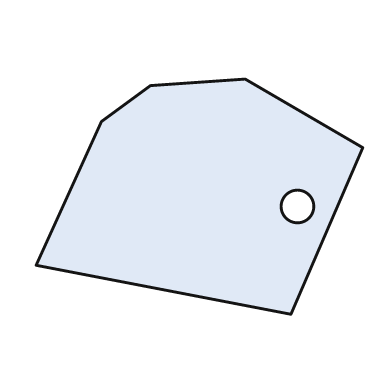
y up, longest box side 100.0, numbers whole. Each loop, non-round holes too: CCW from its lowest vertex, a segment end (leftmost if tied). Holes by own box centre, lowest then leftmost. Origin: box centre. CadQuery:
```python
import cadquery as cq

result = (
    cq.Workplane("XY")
    .moveTo(28.0, -36.0)
    .lineTo(50.0, 15.0)
    .lineTo(14.0, 36.0)
    .lineTo(-15.0, 34.0)
    .lineTo(-30.0, 23.0)
    .lineTo(-50.0, -21.0)
    .close()
    .moveTo(30.0, -3.0)
    .circle(5.0)
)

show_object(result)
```